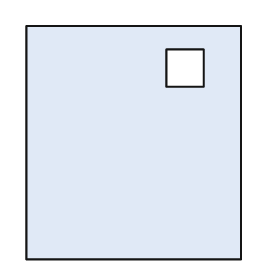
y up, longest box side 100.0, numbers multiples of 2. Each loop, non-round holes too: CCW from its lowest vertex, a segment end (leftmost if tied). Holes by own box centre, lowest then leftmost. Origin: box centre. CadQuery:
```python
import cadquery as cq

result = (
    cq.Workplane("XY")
    .moveTo(-46.0, -50.0)
    .lineTo(46.0, -50.0)
    .lineTo(46.0, 50.0)
    .lineTo(-46.0, 50.0)
    .close()
    .moveTo(14.0, 24.0)
    .lineTo(30.0, 24.0)
    .lineTo(30.0, 40.0)
    .lineTo(14.0, 40.0)
    .close()
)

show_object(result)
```